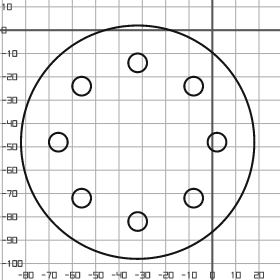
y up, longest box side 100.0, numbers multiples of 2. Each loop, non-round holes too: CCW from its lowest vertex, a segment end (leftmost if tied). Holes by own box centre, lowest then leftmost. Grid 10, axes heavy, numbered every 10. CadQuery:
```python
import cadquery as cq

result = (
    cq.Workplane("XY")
    .moveTo(-32.0, -48.0)
    .circle(50.0)
    .moveTo(-32.0, -82.0)
    .circle(4.0)
    .moveTo(-56.0, -72.0)
    .circle(4.0)
    .moveTo(-8.0, -72.0)
    .circle(4.0)
    .moveTo(-66.0, -48.0)
    .circle(4.0)
    .moveTo(2.0, -48.0)
    .circle(4.0)
    .moveTo(-56.0, -24.0)
    .circle(4.0)
    .moveTo(-8.0, -24.0)
    .circle(4.0)
    .moveTo(-32.0, -14.0)
    .circle(4.0)
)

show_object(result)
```